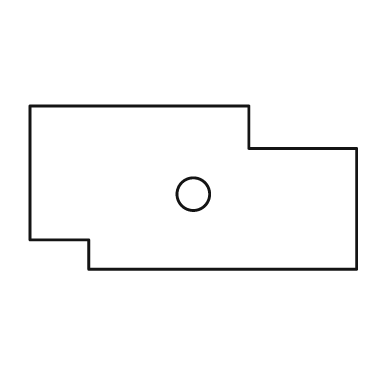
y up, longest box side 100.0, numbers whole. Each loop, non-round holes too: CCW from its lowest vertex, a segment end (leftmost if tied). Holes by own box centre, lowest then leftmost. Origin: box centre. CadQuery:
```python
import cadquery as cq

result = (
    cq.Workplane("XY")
    .moveTo(-32.0, -25.0)
    .lineTo(50.0, -25.0)
    .lineTo(50.0, 12.0)
    .lineTo(17.0, 12.0)
    .lineTo(17.0, 25.0)
    .lineTo(-50.0, 25.0)
    .lineTo(-50.0, -16.0)
    .lineTo(-32.0, -16.0)
    .close()
    .moveTo(0.0, -2.0)
    .circle(5.0)
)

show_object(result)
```